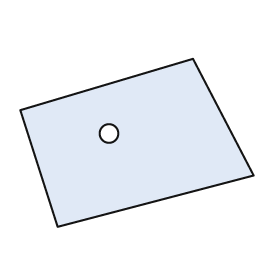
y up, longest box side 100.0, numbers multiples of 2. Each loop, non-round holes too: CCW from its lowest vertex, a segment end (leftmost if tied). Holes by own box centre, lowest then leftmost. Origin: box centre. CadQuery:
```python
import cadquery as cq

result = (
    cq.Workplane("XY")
    .moveTo(-34.0, -36.0)
    .lineTo(50.0, -14.0)
    .lineTo(24.0, 36.0)
    .lineTo(-50.0, 14.0)
    .close()
    .moveTo(-12.0, 4.0)
    .circle(4.0)
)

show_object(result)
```